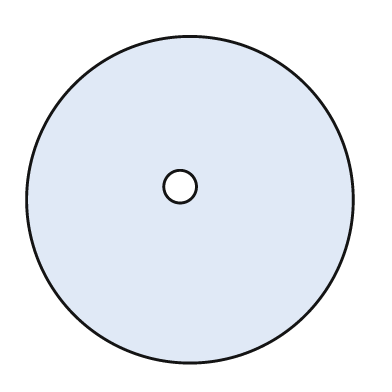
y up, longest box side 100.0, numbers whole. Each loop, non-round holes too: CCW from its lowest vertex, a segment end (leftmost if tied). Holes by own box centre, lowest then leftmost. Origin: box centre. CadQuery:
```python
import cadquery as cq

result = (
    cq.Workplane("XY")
    .moveTo(0.0, 0.0)
    .circle(50.0)
    .moveTo(-3.0, 4.0)
    .circle(5.0)
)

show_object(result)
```